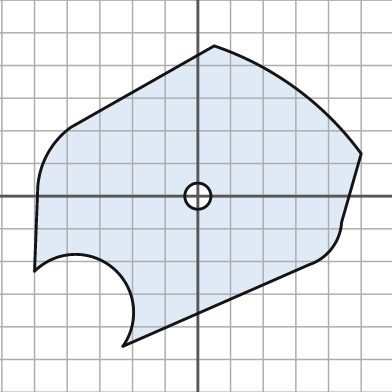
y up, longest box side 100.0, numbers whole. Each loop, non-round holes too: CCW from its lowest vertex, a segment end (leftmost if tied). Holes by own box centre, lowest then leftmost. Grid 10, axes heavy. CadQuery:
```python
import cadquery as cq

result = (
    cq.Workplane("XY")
    .moveTo(-23.0, -46.0)
    .lineTo(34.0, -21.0)
    .threePointArc((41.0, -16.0), (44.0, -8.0))
    .lineTo(50.0, 13.0)
    .threePointArc((30.0, 33.0), (5.0, 46.0))
    .lineTo(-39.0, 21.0)
    .threePointArc((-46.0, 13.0), (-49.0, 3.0))
    .lineTo(-50.0, -23.0)
    .threePointArc((-26.0, -22.0), (-23.0, -46.0))
    .close()
    .moveTo(0.0, 0.0)
    .circle(4.0)
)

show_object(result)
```